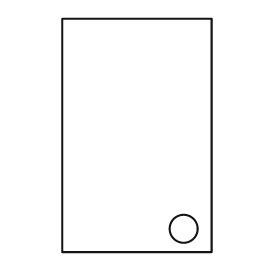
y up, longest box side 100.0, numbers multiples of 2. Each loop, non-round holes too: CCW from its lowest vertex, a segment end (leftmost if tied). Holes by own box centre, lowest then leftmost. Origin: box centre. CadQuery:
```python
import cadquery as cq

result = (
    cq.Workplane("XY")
    .moveTo(-32.0, -50.0)
    .lineTo(32.0, -50.0)
    .lineTo(32.0, 50.0)
    .lineTo(-32.0, 50.0)
    .close()
    .moveTo(20.0, -40.0)
    .circle(6.0)
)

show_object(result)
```